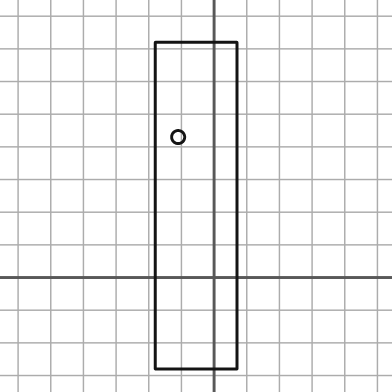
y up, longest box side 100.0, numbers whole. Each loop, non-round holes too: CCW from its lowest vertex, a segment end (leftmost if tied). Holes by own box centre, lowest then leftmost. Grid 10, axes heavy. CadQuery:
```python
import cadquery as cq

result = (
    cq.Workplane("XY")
    .moveTo(-18.0, -28.0)
    .lineTo(7.0, -28.0)
    .lineTo(7.0, 72.0)
    .lineTo(-18.0, 72.0)
    .close()
    .moveTo(-11.0, 43.0)
    .circle(2.0)
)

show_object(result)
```